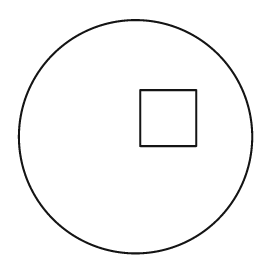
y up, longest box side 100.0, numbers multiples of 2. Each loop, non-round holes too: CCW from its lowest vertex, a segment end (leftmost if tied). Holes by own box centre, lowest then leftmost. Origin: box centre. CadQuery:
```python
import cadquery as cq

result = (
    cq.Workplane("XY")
    .moveTo(0.0, 0.0)
    .circle(50.0)
    .moveTo(2.0, -4.0)
    .lineTo(26.0, -4.0)
    .lineTo(26.0, 20.0)
    .lineTo(2.0, 20.0)
    .close()
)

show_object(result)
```